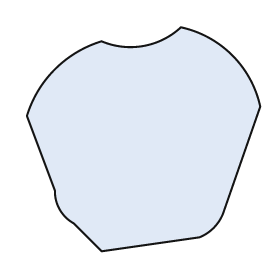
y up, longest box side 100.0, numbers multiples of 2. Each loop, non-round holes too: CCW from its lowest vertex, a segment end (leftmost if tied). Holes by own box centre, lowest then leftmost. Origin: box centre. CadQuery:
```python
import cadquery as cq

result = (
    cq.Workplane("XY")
    .moveTo(-18.0, -48.0)
    .lineTo(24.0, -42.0)
    .threePointArc((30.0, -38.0), (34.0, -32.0))
    .lineTo(50.0, 14.0)
    .threePointArc((38.0, 36.0), (16.0, 48.0))
    .threePointArc((0.0, 40.0), (-18.0, 42.0))
    .threePointArc((-38.0, 30.0), (-50.0, 10.0))
    .lineTo(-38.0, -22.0)
    .threePointArc((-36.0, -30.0), (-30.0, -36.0))
    .close()
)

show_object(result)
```